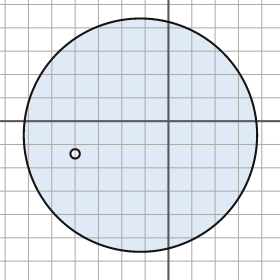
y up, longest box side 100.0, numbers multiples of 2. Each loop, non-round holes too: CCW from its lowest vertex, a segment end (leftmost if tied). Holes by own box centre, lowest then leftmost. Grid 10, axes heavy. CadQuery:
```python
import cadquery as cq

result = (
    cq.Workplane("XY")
    .moveTo(-12.0, -6.0)
    .circle(50.0)
    .moveTo(-40.0, -14.0)
    .circle(2.0)
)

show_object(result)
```